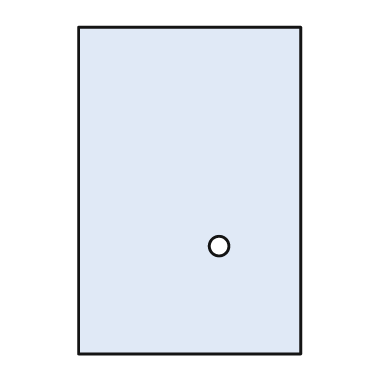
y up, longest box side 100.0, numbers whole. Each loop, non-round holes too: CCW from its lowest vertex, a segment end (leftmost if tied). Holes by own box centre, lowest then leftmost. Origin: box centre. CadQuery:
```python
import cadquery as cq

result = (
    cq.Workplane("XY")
    .moveTo(-34.0, -50.0)
    .lineTo(34.0, -50.0)
    .lineTo(34.0, 50.0)
    .lineTo(-34.0, 50.0)
    .close()
    .moveTo(9.0, -17.0)
    .circle(3.0)
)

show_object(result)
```